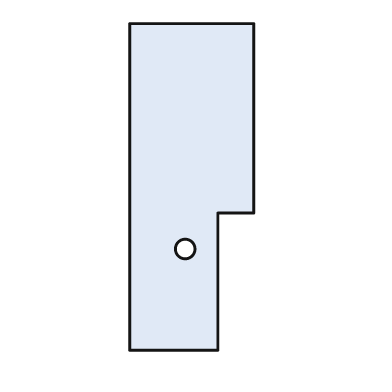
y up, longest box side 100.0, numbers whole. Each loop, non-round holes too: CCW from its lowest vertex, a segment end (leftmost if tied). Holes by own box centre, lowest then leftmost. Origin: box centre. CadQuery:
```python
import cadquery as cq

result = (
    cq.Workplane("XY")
    .moveTo(-19.0, -50.0)
    .lineTo(8.0, -50.0)
    .lineTo(8.0, -8.0)
    .lineTo(19.0, -8.0)
    .lineTo(19.0, 50.0)
    .lineTo(-19.0, 50.0)
    .close()
    .moveTo(-2.0, -19.0)
    .circle(3.0)
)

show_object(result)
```